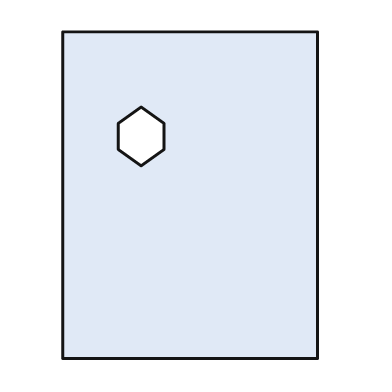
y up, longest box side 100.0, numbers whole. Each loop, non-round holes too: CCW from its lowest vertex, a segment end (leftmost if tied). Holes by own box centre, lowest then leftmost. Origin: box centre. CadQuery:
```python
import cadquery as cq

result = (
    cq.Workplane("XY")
    .moveTo(-39.0, -50.0)
    .lineTo(39.0, -50.0)
    .lineTo(39.0, 50.0)
    .lineTo(-39.0, 50.0)
    .close()
    .moveTo(-15.0, 9.0)
    .lineTo(-8.0, 14.0)
    .lineTo(-8.0, 22.0)
    .lineTo(-15.0, 27.0)
    .lineTo(-22.0, 22.0)
    .lineTo(-22.0, 14.0)
    .close()
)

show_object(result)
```